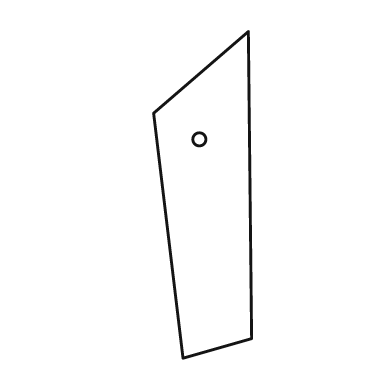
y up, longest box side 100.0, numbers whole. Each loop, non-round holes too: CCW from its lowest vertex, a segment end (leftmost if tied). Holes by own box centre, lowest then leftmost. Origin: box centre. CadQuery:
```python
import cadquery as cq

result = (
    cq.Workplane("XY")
    .moveTo(-6.0, -50.0)
    .lineTo(15.0, -44.0)
    .lineTo(14.0, 50.0)
    .lineTo(-15.0, 25.0)
    .close()
    .moveTo(-1.0, 17.0)
    .circle(2.0)
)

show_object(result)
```